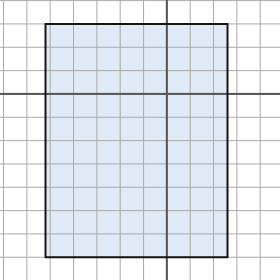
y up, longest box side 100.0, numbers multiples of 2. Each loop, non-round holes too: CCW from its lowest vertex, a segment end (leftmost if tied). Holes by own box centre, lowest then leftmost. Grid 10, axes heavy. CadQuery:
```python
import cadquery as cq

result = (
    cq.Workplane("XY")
    .moveTo(-52.0, -70.0)
    .lineTo(26.0, -70.0)
    .lineTo(26.0, 30.0)
    .lineTo(-52.0, 30.0)
    .close()
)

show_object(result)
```